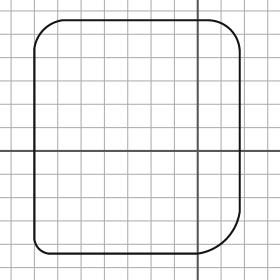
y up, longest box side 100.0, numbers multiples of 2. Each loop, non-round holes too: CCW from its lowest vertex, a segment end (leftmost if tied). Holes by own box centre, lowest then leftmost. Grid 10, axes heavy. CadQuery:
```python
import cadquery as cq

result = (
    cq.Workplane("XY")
    .moveTo(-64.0, -44.0)
    .lineTo(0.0, -44.0)
    .threePointArc((12.0, -38.0), (18.0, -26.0))
    .lineTo(18.0, 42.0)
    .threePointArc((14.0, 52.0), (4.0, 56.0))
    .lineTo(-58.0, 56.0)
    .threePointArc((-66.0, 52.0), (-70.0, 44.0))
    .lineTo(-70.0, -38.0)
    .threePointArc((-68.0, -42.0), (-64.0, -44.0))
    .close()
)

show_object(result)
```